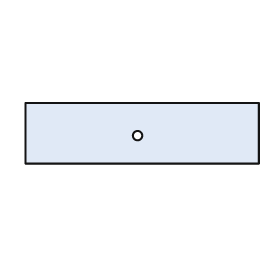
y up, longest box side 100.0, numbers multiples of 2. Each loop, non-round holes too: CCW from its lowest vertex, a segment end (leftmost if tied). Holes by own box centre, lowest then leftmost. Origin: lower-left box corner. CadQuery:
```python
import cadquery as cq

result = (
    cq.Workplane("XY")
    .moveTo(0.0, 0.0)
    .lineTo(100.0, 0.0)
    .lineTo(100.0, 26.0)
    .lineTo(0.0, 26.0)
    .close()
    .moveTo(48.0, 12.0)
    .circle(2.0)
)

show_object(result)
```